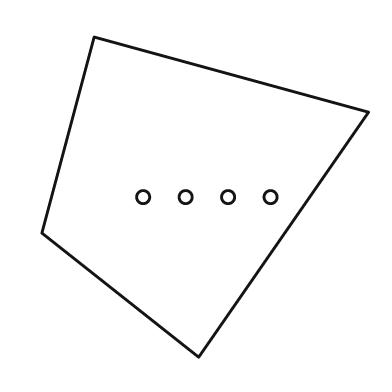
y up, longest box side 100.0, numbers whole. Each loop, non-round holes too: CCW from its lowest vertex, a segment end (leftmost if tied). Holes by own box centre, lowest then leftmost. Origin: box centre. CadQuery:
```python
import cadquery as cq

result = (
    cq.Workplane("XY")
    .moveTo(-2.0, -49.0)
    .lineTo(50.0, 26.0)
    .lineTo(-34.0, 49.0)
    .lineTo(-50.0, -11.0)
    .close()
    .moveTo(-19.0, 0.0)
    .circle(2.0)
    .moveTo(-6.0, 0.0)
    .circle(2.0)
    .moveTo(7.0, 0.0)
    .circle(2.0)
    .moveTo(20.0, 0.0)
    .circle(2.0)
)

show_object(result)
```